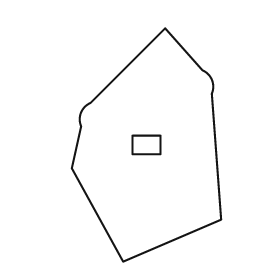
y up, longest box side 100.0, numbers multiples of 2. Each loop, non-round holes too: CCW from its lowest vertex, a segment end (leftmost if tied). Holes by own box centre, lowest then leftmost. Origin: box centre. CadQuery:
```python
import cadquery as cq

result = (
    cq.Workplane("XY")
    .moveTo(-10.0, -50.0)
    .lineTo(32.0, -32.0)
    .lineTo(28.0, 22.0)
    .threePointArc((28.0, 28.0), (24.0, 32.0))
    .lineTo(8.0, 50.0)
    .lineTo(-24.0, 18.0)
    .threePointArc((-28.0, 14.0), (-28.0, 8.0))
    .lineTo(-32.0, -10.0)
    .close()
    .moveTo(-6.0, -4.0)
    .lineTo(6.0, -4.0)
    .lineTo(6.0, 4.0)
    .lineTo(-6.0, 4.0)
    .close()
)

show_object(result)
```